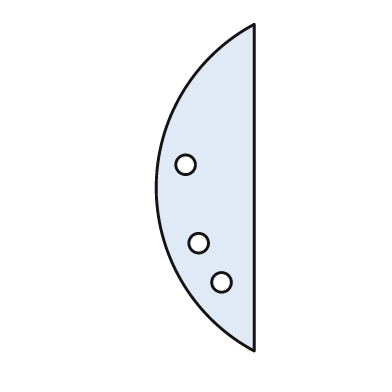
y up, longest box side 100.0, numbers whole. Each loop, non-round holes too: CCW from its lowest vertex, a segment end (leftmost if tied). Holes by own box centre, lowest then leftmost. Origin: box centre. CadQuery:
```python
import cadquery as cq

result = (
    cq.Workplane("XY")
    .moveTo(15.0, -50.0)
    .lineTo(15.0, 50.0)
    .threePointArc((-15.0, 0.0), (15.0, -50.0))
    .close()
    .moveTo(5.0, -29.0)
    .circle(3.0)
    .moveTo(-2.0, -17.0)
    .circle(3.0)
    .moveTo(-6.0, 7.0)
    .circle(3.0)
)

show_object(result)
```